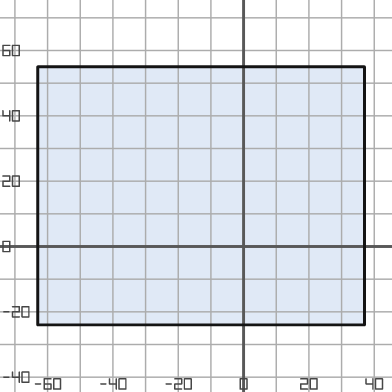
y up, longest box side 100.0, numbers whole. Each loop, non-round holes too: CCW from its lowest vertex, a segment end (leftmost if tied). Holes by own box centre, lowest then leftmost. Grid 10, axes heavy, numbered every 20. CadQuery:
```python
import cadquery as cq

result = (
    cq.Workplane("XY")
    .moveTo(-63.0, -24.0)
    .lineTo(37.0, -24.0)
    .lineTo(37.0, 55.0)
    .lineTo(-63.0, 55.0)
    .close()
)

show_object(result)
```